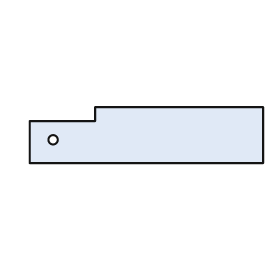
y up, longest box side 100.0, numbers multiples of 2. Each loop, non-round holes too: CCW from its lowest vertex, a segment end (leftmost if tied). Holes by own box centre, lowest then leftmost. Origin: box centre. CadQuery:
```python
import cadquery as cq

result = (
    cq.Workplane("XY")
    .moveTo(-50.0, -12.0)
    .lineTo(50.0, -12.0)
    .lineTo(50.0, 12.0)
    .lineTo(-22.0, 12.0)
    .lineTo(-22.0, 6.0)
    .lineTo(-50.0, 6.0)
    .close()
    .moveTo(-40.0, -2.0)
    .circle(2.0)
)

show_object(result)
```